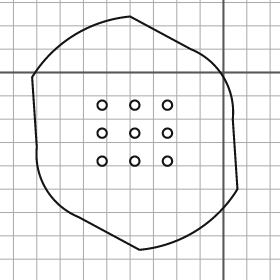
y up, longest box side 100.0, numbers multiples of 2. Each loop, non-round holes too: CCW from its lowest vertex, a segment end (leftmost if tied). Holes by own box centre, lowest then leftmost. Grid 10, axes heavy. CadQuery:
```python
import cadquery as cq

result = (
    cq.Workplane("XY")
    .moveTo(-36.0, -76.0)
    .threePointArc((-12.0, -68.0), (6.0, -50.0))
    .lineTo(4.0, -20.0)
    .threePointArc((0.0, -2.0), (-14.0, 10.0))
    .lineTo(-40.0, 24.0)
    .threePointArc((-64.0, 16.0), (-82.0, -2.0))
    .lineTo(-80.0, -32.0)
    .threePointArc((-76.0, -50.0), (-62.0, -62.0))
    .close()
    .moveTo(-52.0, -38.0)
    .circle(2.0)
    .moveTo(-38.0, -38.0)
    .circle(2.0)
    .moveTo(-24.0, -38.0)
    .circle(2.0)
    .moveTo(-52.0, -26.0)
    .circle(2.0)
    .moveTo(-38.0, -26.0)
    .circle(2.0)
    .moveTo(-24.0, -26.0)
    .circle(2.0)
    .moveTo(-52.0, -14.0)
    .circle(2.0)
    .moveTo(-38.0, -14.0)
    .circle(2.0)
    .moveTo(-24.0, -14.0)
    .circle(2.0)
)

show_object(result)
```